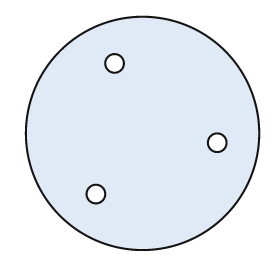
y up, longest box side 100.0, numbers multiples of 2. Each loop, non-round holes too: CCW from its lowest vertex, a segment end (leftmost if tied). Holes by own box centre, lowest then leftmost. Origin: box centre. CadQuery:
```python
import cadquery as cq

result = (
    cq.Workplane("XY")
    .moveTo(0.0, 0.0)
    .circle(50.0)
    .moveTo(-20.0, -26.0)
    .circle(4.0)
    .moveTo(32.0, -4.0)
    .circle(4.0)
    .moveTo(-12.0, 30.0)
    .circle(4.0)
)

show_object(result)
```